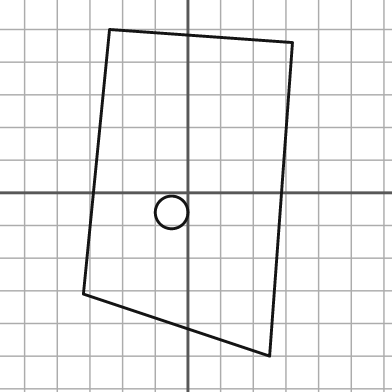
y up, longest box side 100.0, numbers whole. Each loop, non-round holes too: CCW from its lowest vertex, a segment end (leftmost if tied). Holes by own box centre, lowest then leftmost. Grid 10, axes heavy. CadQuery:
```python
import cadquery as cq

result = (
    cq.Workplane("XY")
    .moveTo(25.0, -50.0)
    .lineTo(32.0, 46.0)
    .lineTo(-24.0, 50.0)
    .lineTo(-32.0, -31.0)
    .close()
    .moveTo(-5.0, -6.0)
    .circle(5.0)
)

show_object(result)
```